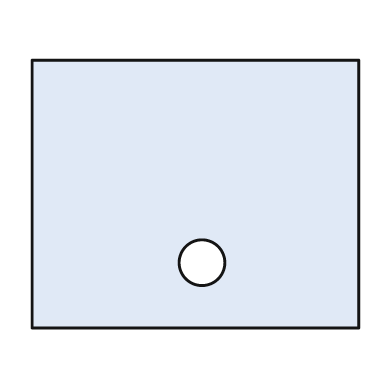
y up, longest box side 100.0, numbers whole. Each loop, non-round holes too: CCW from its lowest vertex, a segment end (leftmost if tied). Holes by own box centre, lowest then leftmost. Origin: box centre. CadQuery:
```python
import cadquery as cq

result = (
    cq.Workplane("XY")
    .moveTo(-50.0, -41.0)
    .lineTo(50.0, -41.0)
    .lineTo(50.0, 41.0)
    .lineTo(-50.0, 41.0)
    .close()
    .moveTo(2.0, -21.0)
    .circle(7.0)
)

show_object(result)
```